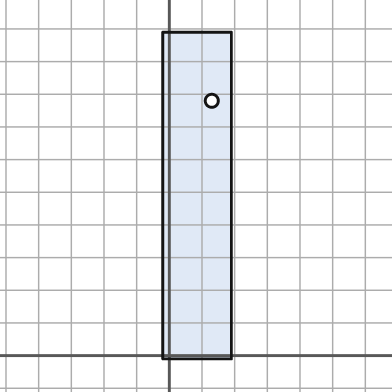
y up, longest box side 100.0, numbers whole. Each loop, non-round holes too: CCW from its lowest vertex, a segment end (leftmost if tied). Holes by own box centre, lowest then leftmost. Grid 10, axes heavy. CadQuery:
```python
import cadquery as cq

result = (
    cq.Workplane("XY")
    .moveTo(-2.0, -1.0)
    .lineTo(19.0, -1.0)
    .lineTo(19.0, 99.0)
    .lineTo(-2.0, 99.0)
    .close()
    .moveTo(13.0, 78.0)
    .circle(2.0)
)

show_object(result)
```